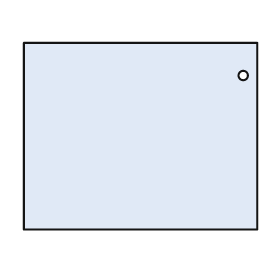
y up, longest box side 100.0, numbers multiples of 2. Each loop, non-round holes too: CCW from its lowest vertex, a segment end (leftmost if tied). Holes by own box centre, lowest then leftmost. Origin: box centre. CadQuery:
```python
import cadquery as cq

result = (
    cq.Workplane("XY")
    .moveTo(-50.0, -40.0)
    .lineTo(50.0, -40.0)
    .lineTo(50.0, 40.0)
    .lineTo(-50.0, 40.0)
    .close()
    .moveTo(44.0, 26.0)
    .circle(2.0)
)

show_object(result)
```